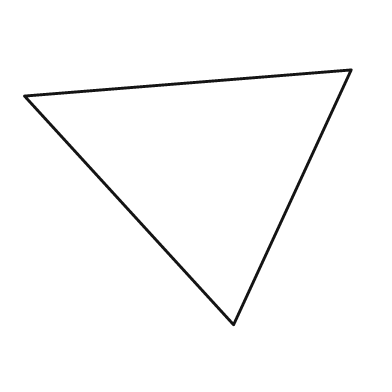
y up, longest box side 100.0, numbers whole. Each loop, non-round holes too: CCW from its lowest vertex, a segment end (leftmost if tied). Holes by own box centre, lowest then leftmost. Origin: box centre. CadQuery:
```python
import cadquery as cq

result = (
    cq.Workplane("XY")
    .moveTo(14.0, -39.0)
    .lineTo(50.0, 39.0)
    .lineTo(-50.0, 31.0)
    .close()
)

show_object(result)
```